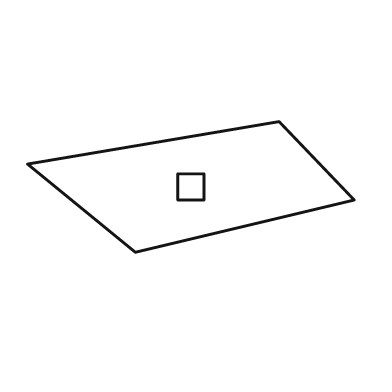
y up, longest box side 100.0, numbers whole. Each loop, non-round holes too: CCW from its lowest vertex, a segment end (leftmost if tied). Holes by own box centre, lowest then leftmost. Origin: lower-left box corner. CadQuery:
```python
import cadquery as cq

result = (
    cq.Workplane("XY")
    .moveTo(33.0, 0.0)
    .lineTo(100.0, 16.0)
    .lineTo(77.0, 40.0)
    .lineTo(0.0, 27.0)
    .close()
    .moveTo(46.0, 16.0)
    .lineTo(54.0, 16.0)
    .lineTo(54.0, 24.0)
    .lineTo(46.0, 24.0)
    .close()
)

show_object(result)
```